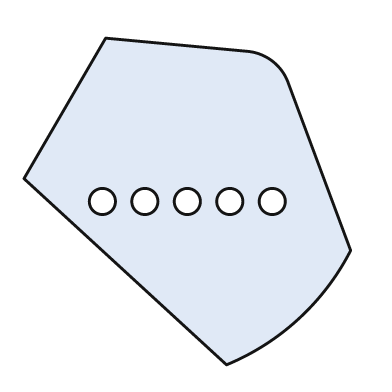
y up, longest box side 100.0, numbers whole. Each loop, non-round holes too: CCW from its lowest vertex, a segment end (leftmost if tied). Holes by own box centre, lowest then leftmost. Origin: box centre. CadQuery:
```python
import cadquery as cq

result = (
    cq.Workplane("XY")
    .moveTo(12.0, -50.0)
    .threePointArc((34.0, -36.0), (50.0, -15.0))
    .lineTo(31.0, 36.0)
    .threePointArc((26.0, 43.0), (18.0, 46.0))
    .lineTo(-25.0, 50.0)
    .lineTo(-50.0, 7.0)
    .close()
    .moveTo(-26.0, 0.0)
    .circle(4.0)
    .moveTo(-13.0, 0.0)
    .circle(4.0)
    .moveTo(0.0, 0.0)
    .circle(4.0)
    .moveTo(13.0, 0.0)
    .circle(4.0)
    .moveTo(26.0, 0.0)
    .circle(4.0)
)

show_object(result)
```